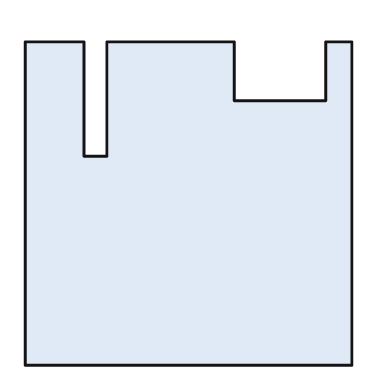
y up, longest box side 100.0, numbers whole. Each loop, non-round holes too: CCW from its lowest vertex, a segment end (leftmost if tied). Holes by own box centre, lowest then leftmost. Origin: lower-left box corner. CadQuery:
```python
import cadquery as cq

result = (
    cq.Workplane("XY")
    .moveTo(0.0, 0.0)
    .lineTo(100.0, 0.0)
    .lineTo(100.0, 99.0)
    .lineTo(92.0, 99.0)
    .lineTo(92.0, 81.0)
    .lineTo(64.0, 81.0)
    .lineTo(64.0, 99.0)
    .lineTo(25.0, 99.0)
    .lineTo(25.0, 64.0)
    .lineTo(18.0, 64.0)
    .lineTo(18.0, 99.0)
    .lineTo(0.0, 99.0)
    .close()
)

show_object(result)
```